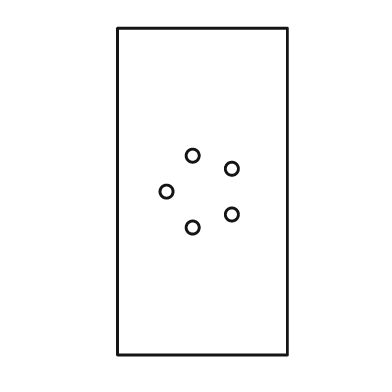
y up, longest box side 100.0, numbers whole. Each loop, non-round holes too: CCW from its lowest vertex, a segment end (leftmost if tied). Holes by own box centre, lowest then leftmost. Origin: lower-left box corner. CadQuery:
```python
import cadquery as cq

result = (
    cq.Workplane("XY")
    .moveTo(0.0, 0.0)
    .lineTo(52.0, 0.0)
    .lineTo(52.0, 100.0)
    .lineTo(0.0, 100.0)
    .close()
    .moveTo(23.0, 39.0)
    .circle(2.0)
    .moveTo(35.0, 43.0)
    .circle(2.0)
    .moveTo(15.0, 50.0)
    .circle(2.0)
    .moveTo(35.0, 57.0)
    .circle(2.0)
    .moveTo(23.0, 61.0)
    .circle(2.0)
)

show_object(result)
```